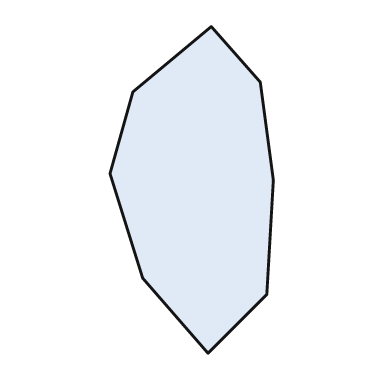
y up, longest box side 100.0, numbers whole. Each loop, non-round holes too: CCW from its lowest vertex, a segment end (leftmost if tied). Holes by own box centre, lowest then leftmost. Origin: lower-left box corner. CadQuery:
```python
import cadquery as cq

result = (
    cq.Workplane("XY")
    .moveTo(30.0, 0.0)
    .lineTo(48.0, 18.0)
    .lineTo(50.0, 53.0)
    .lineTo(46.0, 83.0)
    .lineTo(31.0, 100.0)
    .lineTo(7.0, 80.0)
    .lineTo(0.0, 55.0)
    .lineTo(10.0, 23.0)
    .close()
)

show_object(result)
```